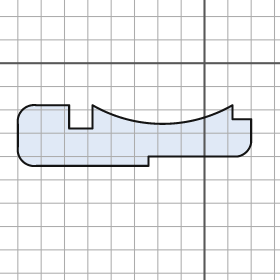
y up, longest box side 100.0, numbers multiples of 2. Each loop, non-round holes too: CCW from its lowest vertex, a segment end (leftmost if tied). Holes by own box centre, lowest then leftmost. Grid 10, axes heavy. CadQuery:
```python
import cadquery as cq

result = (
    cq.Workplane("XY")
    .moveTo(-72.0, -44.0)
    .lineTo(-24.0, -44.0)
    .lineTo(-24.0, -40.0)
    .lineTo(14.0, -40.0)
    .threePointArc((18.0, -38.0), (20.0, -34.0))
    .lineTo(20.0, -24.0)
    .lineTo(12.0, -24.0)
    .lineTo(12.0, -18.0)
    .threePointArc((-18.0, -26.0), (-48.0, -18.0))
    .lineTo(-48.0, -28.0)
    .lineTo(-58.0, -28.0)
    .lineTo(-58.0, -18.0)
    .lineTo(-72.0, -18.0)
    .threePointArc((-78.0, -20.0), (-80.0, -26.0))
    .lineTo(-80.0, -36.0)
    .threePointArc((-78.0, -42.0), (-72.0, -44.0))
    .close()
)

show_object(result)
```